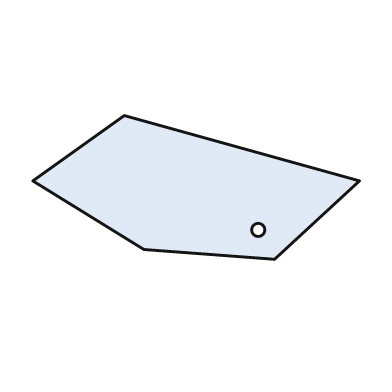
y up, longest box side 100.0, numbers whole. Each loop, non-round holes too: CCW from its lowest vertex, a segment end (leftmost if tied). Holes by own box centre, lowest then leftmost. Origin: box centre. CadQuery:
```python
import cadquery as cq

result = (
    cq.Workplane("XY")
    .moveTo(24.0, -22.0)
    .lineTo(50.0, 2.0)
    .lineTo(-22.0, 22.0)
    .lineTo(-50.0, 2.0)
    .lineTo(-16.0, -19.0)
    .close()
    .moveTo(19.0, -13.0)
    .circle(2.0)
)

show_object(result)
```